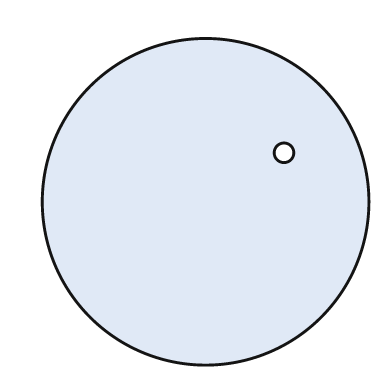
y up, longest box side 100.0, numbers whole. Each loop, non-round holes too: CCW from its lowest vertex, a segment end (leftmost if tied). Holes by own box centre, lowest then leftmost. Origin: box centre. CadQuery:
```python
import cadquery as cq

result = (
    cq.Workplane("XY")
    .moveTo(0.0, 0.0)
    .circle(50.0)
    .moveTo(24.0, 15.0)
    .circle(3.0)
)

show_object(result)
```